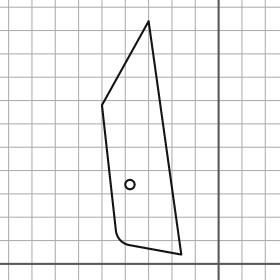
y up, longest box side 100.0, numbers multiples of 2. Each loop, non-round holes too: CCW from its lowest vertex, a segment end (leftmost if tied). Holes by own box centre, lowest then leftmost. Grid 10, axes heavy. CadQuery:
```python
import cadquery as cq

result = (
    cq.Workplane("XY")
    .moveTo(-16.0, 4.0)
    .lineTo(-30.0, 104.0)
    .lineTo(-50.0, 68.0)
    .lineTo(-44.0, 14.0)
    .threePointArc((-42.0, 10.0), (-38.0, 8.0))
    .close()
    .moveTo(-38.0, 34.0)
    .circle(2.0)
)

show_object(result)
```